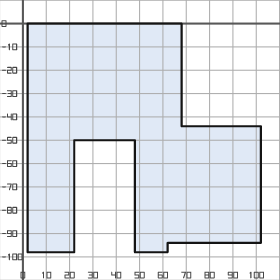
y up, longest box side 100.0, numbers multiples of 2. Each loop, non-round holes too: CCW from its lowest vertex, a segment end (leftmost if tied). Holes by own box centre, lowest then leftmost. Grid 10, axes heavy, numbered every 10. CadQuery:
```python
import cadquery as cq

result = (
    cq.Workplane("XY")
    .moveTo(2.0, -98.0)
    .lineTo(22.0, -98.0)
    .lineTo(22.0, -50.0)
    .lineTo(48.0, -50.0)
    .lineTo(48.0, -98.0)
    .lineTo(62.0, -98.0)
    .lineTo(62.0, -94.0)
    .lineTo(102.0, -94.0)
    .lineTo(102.0, -44.0)
    .lineTo(68.0, -44.0)
    .lineTo(68.0, 0.0)
    .lineTo(2.0, 0.0)
    .close()
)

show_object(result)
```